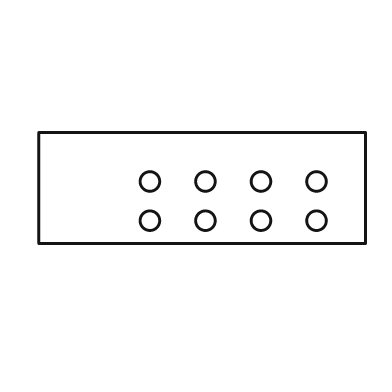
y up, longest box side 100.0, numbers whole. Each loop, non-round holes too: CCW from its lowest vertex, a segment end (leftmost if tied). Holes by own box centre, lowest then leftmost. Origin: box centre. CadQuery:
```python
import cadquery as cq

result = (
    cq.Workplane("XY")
    .moveTo(-50.0, -17.0)
    .lineTo(50.0, -17.0)
    .lineTo(50.0, 17.0)
    .lineTo(-50.0, 17.0)
    .close()
    .moveTo(-16.0, -10.0)
    .circle(3.0)
    .moveTo(1.0, -10.0)
    .circle(3.0)
    .moveTo(18.0, -10.0)
    .circle(3.0)
    .moveTo(35.0, -10.0)
    .circle(3.0)
    .moveTo(-16.0, 2.0)
    .circle(3.0)
    .moveTo(1.0, 2.0)
    .circle(3.0)
    .moveTo(18.0, 2.0)
    .circle(3.0)
    .moveTo(35.0, 2.0)
    .circle(3.0)
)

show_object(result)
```